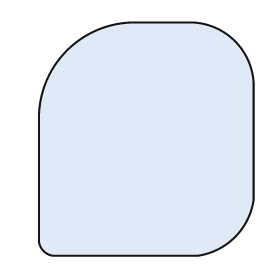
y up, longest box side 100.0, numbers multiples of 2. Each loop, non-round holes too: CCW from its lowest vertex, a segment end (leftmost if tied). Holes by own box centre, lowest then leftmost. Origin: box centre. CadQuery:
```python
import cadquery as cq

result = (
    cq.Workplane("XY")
    .moveTo(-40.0, -50.0)
    .lineTo(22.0, -50.0)
    .threePointArc((38.0, -42.0), (46.0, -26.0))
    .lineTo(46.0, 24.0)
    .threePointArc((38.0, 42.0), (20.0, 50.0))
    .lineTo(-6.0, 50.0)
    .threePointArc((-34.0, 38.0), (-46.0, 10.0))
    .lineTo(-46.0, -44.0)
    .threePointArc((-44.0, -48.0), (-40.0, -50.0))
    .close()
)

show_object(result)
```